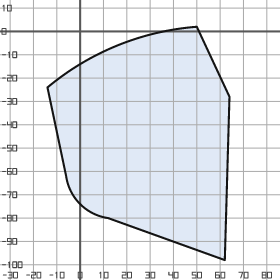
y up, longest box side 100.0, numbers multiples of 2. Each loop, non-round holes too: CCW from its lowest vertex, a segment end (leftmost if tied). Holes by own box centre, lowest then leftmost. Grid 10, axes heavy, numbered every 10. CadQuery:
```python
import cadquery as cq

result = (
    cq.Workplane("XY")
    .moveTo(62.0, -98.0)
    .lineTo(64.0, -28.0)
    .lineTo(50.0, 2.0)
    .threePointArc((16.0, -6.0), (-14.0, -24.0))
    .lineTo(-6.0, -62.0)
    .threePointArc((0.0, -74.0), (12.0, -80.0))
    .close()
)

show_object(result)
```